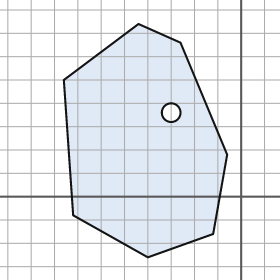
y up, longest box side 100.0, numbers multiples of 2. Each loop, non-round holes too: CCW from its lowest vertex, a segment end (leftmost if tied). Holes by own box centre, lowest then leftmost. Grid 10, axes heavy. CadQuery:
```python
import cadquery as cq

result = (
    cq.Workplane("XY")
    .moveTo(-40.0, -26.0)
    .lineTo(-12.0, -16.0)
    .lineTo(-6.0, 18.0)
    .lineTo(-26.0, 66.0)
    .lineTo(-44.0, 74.0)
    .lineTo(-76.0, 50.0)
    .lineTo(-72.0, -8.0)
    .close()
    .moveTo(-30.0, 36.0)
    .circle(4.0)
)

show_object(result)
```